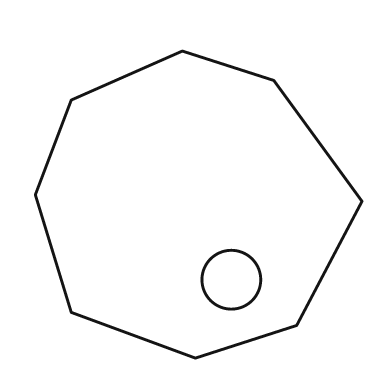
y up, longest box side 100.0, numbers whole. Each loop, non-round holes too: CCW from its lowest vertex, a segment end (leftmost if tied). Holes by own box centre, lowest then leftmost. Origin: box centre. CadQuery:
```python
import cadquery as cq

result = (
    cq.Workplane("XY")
    .moveTo(-1.0, -47.0)
    .lineTo(30.0, -37.0)
    .lineTo(50.0, 1.0)
    .lineTo(23.0, 38.0)
    .lineTo(-5.0, 47.0)
    .lineTo(-39.0, 32.0)
    .lineTo(-50.0, 3.0)
    .lineTo(-39.0, -33.0)
    .close()
    .moveTo(10.0, -23.0)
    .circle(9.0)
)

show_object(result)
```